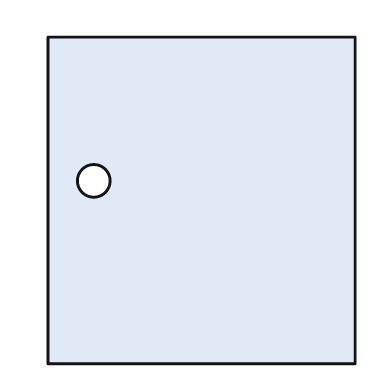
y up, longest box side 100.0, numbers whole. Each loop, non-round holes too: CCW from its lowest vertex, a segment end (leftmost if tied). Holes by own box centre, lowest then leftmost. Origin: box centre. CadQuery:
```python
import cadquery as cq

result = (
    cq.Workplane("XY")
    .moveTo(-47.0, -50.0)
    .lineTo(47.0, -50.0)
    .lineTo(47.0, 50.0)
    .lineTo(-47.0, 50.0)
    .close()
    .moveTo(-33.0, 6.0)
    .circle(5.0)
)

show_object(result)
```